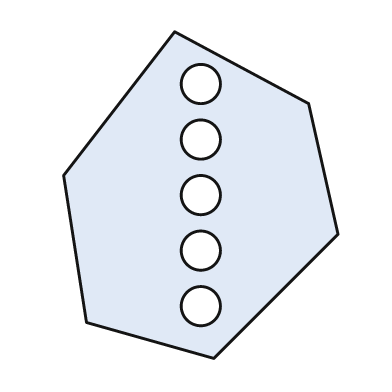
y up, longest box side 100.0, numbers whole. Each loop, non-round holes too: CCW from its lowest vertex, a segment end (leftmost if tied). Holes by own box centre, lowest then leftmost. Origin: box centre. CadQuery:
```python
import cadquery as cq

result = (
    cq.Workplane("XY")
    .moveTo(4.0, -50.0)
    .lineTo(42.0, -12.0)
    .lineTo(33.0, 28.0)
    .lineTo(-8.0, 50.0)
    .lineTo(-42.0, 6.0)
    .lineTo(-35.0, -39.0)
    .close()
    .moveTo(0.0, -34.0)
    .circle(6.0)
    .moveTo(0.0, -17.0)
    .circle(6.0)
    .moveTo(0.0, 0.0)
    .circle(6.0)
    .moveTo(0.0, 17.0)
    .circle(6.0)
    .moveTo(0.0, 34.0)
    .circle(6.0)
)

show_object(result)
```